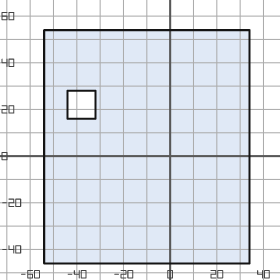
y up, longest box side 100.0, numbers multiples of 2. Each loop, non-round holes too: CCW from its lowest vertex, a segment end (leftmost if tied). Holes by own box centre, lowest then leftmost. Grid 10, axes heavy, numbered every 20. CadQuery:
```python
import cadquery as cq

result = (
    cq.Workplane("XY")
    .moveTo(-54.0, -46.0)
    .lineTo(34.0, -46.0)
    .lineTo(34.0, 54.0)
    .lineTo(-54.0, 54.0)
    .close()
    .moveTo(-44.0, 16.0)
    .lineTo(-32.0, 16.0)
    .lineTo(-32.0, 28.0)
    .lineTo(-44.0, 28.0)
    .close()
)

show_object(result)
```